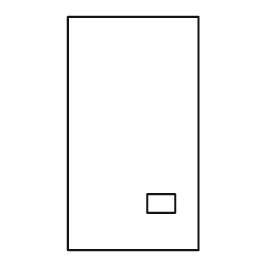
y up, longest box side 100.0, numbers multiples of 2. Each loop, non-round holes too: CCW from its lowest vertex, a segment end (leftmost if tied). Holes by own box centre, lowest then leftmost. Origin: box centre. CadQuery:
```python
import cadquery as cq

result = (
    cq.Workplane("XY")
    .moveTo(-28.0, -50.0)
    .lineTo(28.0, -50.0)
    .lineTo(28.0, 50.0)
    .lineTo(-28.0, 50.0)
    .close()
    .moveTo(6.0, -34.0)
    .lineTo(18.0, -34.0)
    .lineTo(18.0, -26.0)
    .lineTo(6.0, -26.0)
    .close()
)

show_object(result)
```